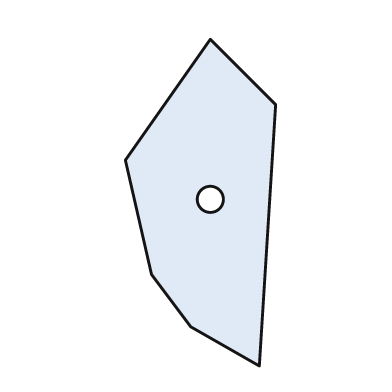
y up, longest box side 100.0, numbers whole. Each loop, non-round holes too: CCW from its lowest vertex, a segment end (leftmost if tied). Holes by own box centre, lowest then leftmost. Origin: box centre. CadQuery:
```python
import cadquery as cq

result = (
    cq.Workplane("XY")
    .moveTo(18.0, -50.0)
    .lineTo(23.0, 30.0)
    .lineTo(3.0, 50.0)
    .lineTo(-23.0, 13.0)
    .lineTo(-15.0, -22.0)
    .lineTo(-3.0, -38.0)
    .close()
    .moveTo(3.0, 1.0)
    .circle(4.0)
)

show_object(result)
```